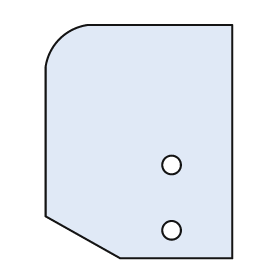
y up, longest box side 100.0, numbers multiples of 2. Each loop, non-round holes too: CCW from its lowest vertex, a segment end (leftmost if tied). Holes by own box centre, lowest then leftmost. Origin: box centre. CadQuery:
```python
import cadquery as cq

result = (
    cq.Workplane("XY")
    .moveTo(-8.0, -50.0)
    .lineTo(40.0, -50.0)
    .lineTo(40.0, 50.0)
    .lineTo(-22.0, 50.0)
    .threePointArc((-34.0, 44.0), (-40.0, 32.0))
    .lineTo(-40.0, -32.0)
    .close()
    .moveTo(14.0, -38.0)
    .circle(4.0)
    .moveTo(14.0, -10.0)
    .circle(4.0)
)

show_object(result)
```